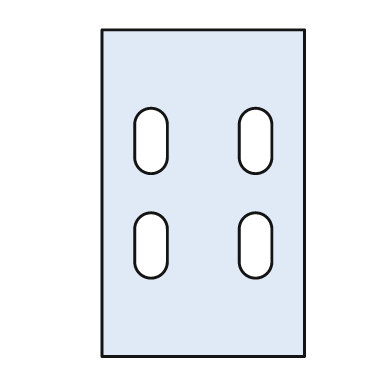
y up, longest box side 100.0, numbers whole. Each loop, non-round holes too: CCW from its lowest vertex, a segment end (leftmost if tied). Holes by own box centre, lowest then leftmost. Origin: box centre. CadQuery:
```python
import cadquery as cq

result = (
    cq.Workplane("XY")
    .moveTo(-31.0, -50.0)
    .lineTo(31.0, -50.0)
    .lineTo(31.0, 50.0)
    .lineTo(-31.0, 50.0)
    .close()
    .moveTo(-21.0, -21.0)
    .threePointArc((-16.0, -26.0), (-11.0, -21.0))
    .lineTo(-11.0, -11.0)
    .threePointArc((-16.0, -6.0), (-21.0, -11.0))
    .close()
    .moveTo(11.0, -21.0)
    .threePointArc((16.0, -26.0), (21.0, -21.0))
    .lineTo(21.0, -11.0)
    .threePointArc((16.0, -6.0), (11.0, -11.0))
    .close()
    .moveTo(-21.0, 11.0)
    .threePointArc((-16.0, 6.0), (-11.0, 11.0))
    .lineTo(-11.0, 21.0)
    .threePointArc((-16.0, 26.0), (-21.0, 21.0))
    .close()
    .moveTo(11.0, 11.0)
    .threePointArc((16.0, 6.0), (21.0, 11.0))
    .lineTo(21.0, 21.0)
    .threePointArc((16.0, 26.0), (11.0, 21.0))
    .close()
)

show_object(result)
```